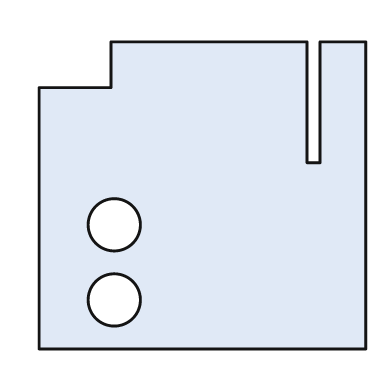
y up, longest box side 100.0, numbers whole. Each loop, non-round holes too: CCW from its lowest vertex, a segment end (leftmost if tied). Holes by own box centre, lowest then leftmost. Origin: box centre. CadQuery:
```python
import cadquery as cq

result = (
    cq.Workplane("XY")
    .moveTo(-50.0, -47.0)
    .lineTo(50.0, -47.0)
    .lineTo(50.0, 47.0)
    .lineTo(36.0, 47.0)
    .lineTo(36.0, 10.0)
    .lineTo(32.0, 10.0)
    .lineTo(32.0, 47.0)
    .lineTo(-28.0, 47.0)
    .lineTo(-28.0, 33.0)
    .lineTo(-50.0, 33.0)
    .close()
    .moveTo(-27.0, -32.0)
    .circle(8.0)
    .moveTo(-27.0, -9.0)
    .circle(8.0)
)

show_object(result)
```